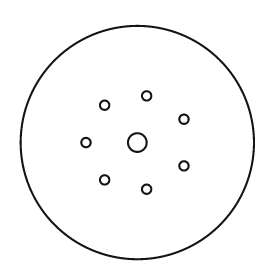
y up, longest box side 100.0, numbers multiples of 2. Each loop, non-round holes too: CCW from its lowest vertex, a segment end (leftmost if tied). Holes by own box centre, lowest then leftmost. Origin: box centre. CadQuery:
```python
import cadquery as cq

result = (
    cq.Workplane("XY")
    .moveTo(0.0, 0.0)
    .circle(50.0)
    .moveTo(4.0, -20.0)
    .circle(2.0)
    .moveTo(-14.0, -16.0)
    .circle(2.0)
    .moveTo(20.0, -10.0)
    .circle(2.0)
    .moveTo(-22.0, 0.0)
    .circle(2.0)
    .moveTo(0.0, 0.0)
    .circle(4.0)
    .moveTo(20.0, 10.0)
    .circle(2.0)
    .moveTo(-14.0, 16.0)
    .circle(2.0)
    .moveTo(4.0, 20.0)
    .circle(2.0)
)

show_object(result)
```